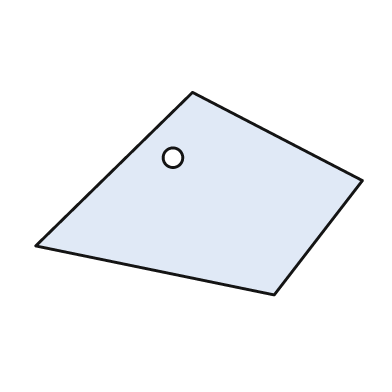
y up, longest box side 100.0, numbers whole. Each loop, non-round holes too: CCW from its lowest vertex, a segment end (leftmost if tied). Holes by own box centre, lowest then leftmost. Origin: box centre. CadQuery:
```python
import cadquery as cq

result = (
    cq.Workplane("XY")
    .moveTo(23.0, -31.0)
    .lineTo(50.0, 4.0)
    .lineTo(-2.0, 31.0)
    .lineTo(-50.0, -16.0)
    .close()
    .moveTo(-8.0, 11.0)
    .circle(3.0)
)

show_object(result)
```